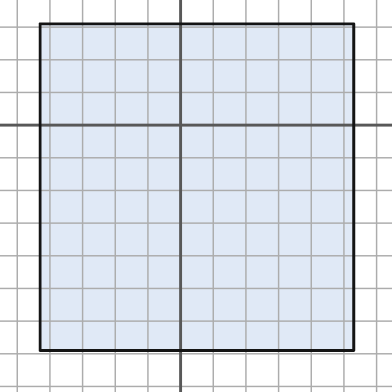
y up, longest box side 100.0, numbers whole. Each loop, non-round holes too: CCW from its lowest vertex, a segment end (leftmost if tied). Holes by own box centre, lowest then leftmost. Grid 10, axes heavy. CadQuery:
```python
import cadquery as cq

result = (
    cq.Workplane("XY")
    .moveTo(-43.0, -69.0)
    .lineTo(53.0, -69.0)
    .lineTo(53.0, 31.0)
    .lineTo(-43.0, 31.0)
    .close()
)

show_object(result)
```